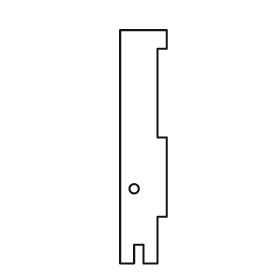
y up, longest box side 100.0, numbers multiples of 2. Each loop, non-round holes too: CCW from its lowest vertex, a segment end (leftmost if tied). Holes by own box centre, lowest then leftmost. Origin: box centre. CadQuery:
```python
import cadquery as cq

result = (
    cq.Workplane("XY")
    .moveTo(-10.0, -50.0)
    .lineTo(-4.0, -50.0)
    .lineTo(-4.0, -42.0)
    .lineTo(0.0, -42.0)
    .lineTo(0.0, -50.0)
    .lineTo(6.0, -50.0)
    .lineTo(6.0, -30.0)
    .lineTo(10.0, -30.0)
    .lineTo(10.0, 4.0)
    .lineTo(6.0, 4.0)
    .lineTo(6.0, 42.0)
    .lineTo(10.0, 42.0)
    .lineTo(10.0, 50.0)
    .lineTo(-10.0, 50.0)
    .close()
    .moveTo(-4.0, -18.0)
    .circle(2.0)
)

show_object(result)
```